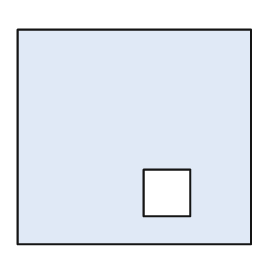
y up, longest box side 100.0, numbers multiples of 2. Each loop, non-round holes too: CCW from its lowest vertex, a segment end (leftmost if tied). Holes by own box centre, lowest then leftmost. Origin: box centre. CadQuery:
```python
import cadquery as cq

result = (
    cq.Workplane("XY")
    .moveTo(-50.0, -46.0)
    .lineTo(50.0, -46.0)
    .lineTo(50.0, 46.0)
    .lineTo(-50.0, 46.0)
    .close()
    .moveTo(4.0, -34.0)
    .lineTo(24.0, -34.0)
    .lineTo(24.0, -14.0)
    .lineTo(4.0, -14.0)
    .close()
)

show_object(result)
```